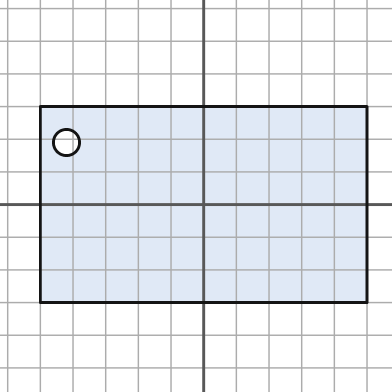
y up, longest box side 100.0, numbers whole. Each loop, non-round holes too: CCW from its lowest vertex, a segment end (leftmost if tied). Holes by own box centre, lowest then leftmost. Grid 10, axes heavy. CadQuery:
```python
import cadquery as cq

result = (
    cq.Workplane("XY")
    .moveTo(-50.0, -30.0)
    .lineTo(50.0, -30.0)
    .lineTo(50.0, 30.0)
    .lineTo(-50.0, 30.0)
    .close()
    .moveTo(-42.0, 19.0)
    .circle(4.0)
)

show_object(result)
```